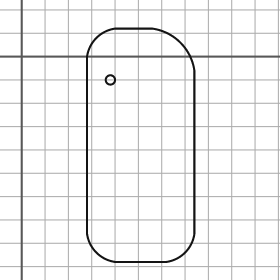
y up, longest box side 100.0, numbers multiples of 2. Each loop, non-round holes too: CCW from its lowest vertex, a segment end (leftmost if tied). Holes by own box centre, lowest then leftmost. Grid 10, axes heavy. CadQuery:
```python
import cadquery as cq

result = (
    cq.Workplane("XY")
    .moveTo(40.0, -88.0)
    .lineTo(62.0, -88.0)
    .threePointArc((70.0, -84.0), (74.0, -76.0))
    .lineTo(74.0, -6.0)
    .threePointArc((68.0, 6.0), (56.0, 12.0))
    .lineTo(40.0, 12.0)
    .threePointArc((32.0, 8.0), (28.0, 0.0))
    .lineTo(28.0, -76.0)
    .threePointArc((32.0, -84.0), (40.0, -88.0))
    .close()
    .moveTo(38.0, -10.0)
    .circle(2.0)
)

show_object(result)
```